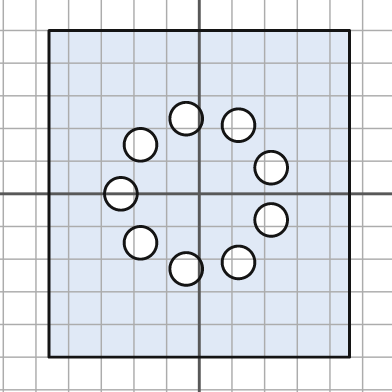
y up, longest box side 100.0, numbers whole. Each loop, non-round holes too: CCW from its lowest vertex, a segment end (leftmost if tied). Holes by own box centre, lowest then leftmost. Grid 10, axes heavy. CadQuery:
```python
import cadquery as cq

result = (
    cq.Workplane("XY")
    .moveTo(-46.0, -50.0)
    .lineTo(46.0, -50.0)
    .lineTo(46.0, 50.0)
    .lineTo(-46.0, 50.0)
    .close()
    .moveTo(-4.0, -23.0)
    .circle(5.0)
    .moveTo(12.0, -21.0)
    .circle(5.0)
    .moveTo(-18.0, -15.0)
    .circle(5.0)
    .moveTo(22.0, -8.0)
    .circle(5.0)
    .moveTo(-24.0, 0.0)
    .circle(5.0)
    .moveTo(22.0, 8.0)
    .circle(5.0)
    .moveTo(-18.0, 15.0)
    .circle(5.0)
    .moveTo(12.0, 21.0)
    .circle(5.0)
    .moveTo(-4.0, 23.0)
    .circle(5.0)
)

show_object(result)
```